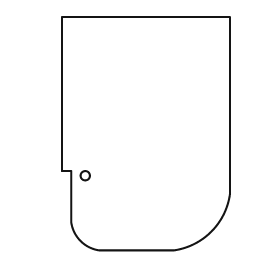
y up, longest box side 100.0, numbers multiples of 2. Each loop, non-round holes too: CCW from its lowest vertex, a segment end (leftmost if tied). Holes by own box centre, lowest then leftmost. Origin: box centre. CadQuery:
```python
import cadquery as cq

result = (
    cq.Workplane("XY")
    .moveTo(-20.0, -50.0)
    .lineTo(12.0, -50.0)
    .threePointArc((28.0, -42.0), (36.0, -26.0))
    .lineTo(36.0, 50.0)
    .lineTo(-36.0, 50.0)
    .lineTo(-36.0, -16.0)
    .lineTo(-32.0, -16.0)
    .lineTo(-32.0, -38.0)
    .threePointArc((-28.0, -46.0), (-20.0, -50.0))
    .close()
    .moveTo(-26.0, -18.0)
    .circle(2.0)
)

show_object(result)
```